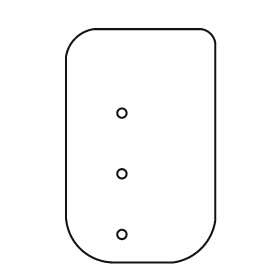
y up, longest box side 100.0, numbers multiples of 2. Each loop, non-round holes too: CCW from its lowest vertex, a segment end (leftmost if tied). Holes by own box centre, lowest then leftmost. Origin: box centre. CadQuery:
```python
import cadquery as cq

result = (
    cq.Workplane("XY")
    .moveTo(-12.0, -50.0)
    .lineTo(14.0, -50.0)
    .threePointArc((26.0, -44.0), (32.0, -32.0))
    .lineTo(32.0, 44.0)
    .threePointArc((30.0, 48.0), (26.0, 50.0))
    .lineTo(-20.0, 50.0)
    .threePointArc((-28.0, 46.0), (-32.0, 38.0))
    .lineTo(-32.0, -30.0)
    .threePointArc((-26.0, -44.0), (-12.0, -50.0))
    .close()
    .moveTo(-8.0, -38.0)
    .circle(2.0)
    .moveTo(-8.0, -12.0)
    .circle(2.0)
    .moveTo(-8.0, 14.0)
    .circle(2.0)
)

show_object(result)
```